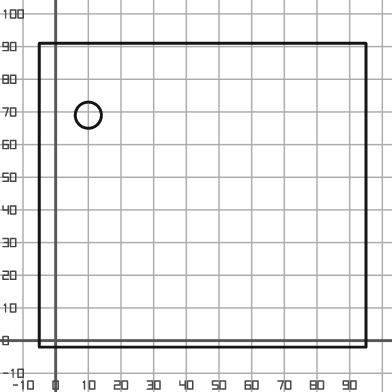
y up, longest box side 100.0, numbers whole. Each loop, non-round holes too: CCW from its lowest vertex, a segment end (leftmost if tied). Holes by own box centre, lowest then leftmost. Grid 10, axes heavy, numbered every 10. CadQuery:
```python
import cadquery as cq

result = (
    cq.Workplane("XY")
    .moveTo(-5.0, -2.0)
    .lineTo(95.0, -2.0)
    .lineTo(95.0, 91.0)
    .lineTo(-5.0, 91.0)
    .close()
    .moveTo(10.0, 69.0)
    .circle(4.0)
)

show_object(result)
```